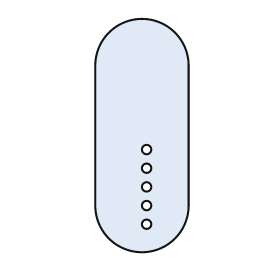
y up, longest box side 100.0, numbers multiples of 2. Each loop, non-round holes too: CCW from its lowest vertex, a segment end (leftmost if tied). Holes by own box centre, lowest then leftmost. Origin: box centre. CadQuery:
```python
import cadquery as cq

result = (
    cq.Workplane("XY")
    .moveTo(-20.0, -30.0)
    .threePointArc((0.0, -50.0), (20.0, -30.0))
    .lineTo(20.0, 30.0)
    .threePointArc((0.0, 50.0), (-20.0, 30.0))
    .close()
    .moveTo(2.0, -38.0)
    .circle(2.0)
    .moveTo(2.0, -30.0)
    .circle(2.0)
    .moveTo(2.0, -22.0)
    .circle(2.0)
    .moveTo(2.0, -14.0)
    .circle(2.0)
    .moveTo(2.0, -6.0)
    .circle(2.0)
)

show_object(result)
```